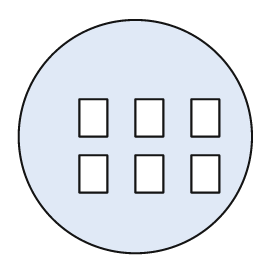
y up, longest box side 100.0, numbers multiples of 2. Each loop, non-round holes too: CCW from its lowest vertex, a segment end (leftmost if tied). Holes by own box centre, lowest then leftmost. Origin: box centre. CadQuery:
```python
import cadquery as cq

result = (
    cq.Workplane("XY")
    .moveTo(0.0, 0.0)
    .circle(50.0)
    .moveTo(-24.0, -24.0)
    .lineTo(-12.0, -24.0)
    .lineTo(-12.0, -8.0)
    .lineTo(-24.0, -8.0)
    .close()
    .moveTo(0.0, -24.0)
    .lineTo(12.0, -24.0)
    .lineTo(12.0, -8.0)
    .lineTo(0.0, -8.0)
    .close()
    .moveTo(24.0, -24.0)
    .lineTo(36.0, -24.0)
    .lineTo(36.0, -8.0)
    .lineTo(24.0, -8.0)
    .close()
    .moveTo(-24.0, 0.0)
    .lineTo(-12.0, 0.0)
    .lineTo(-12.0, 16.0)
    .lineTo(-24.0, 16.0)
    .close()
    .moveTo(0.0, 0.0)
    .lineTo(12.0, 0.0)
    .lineTo(12.0, 16.0)
    .lineTo(0.0, 16.0)
    .close()
    .moveTo(24.0, 0.0)
    .lineTo(36.0, 0.0)
    .lineTo(36.0, 16.0)
    .lineTo(24.0, 16.0)
    .close()
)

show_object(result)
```